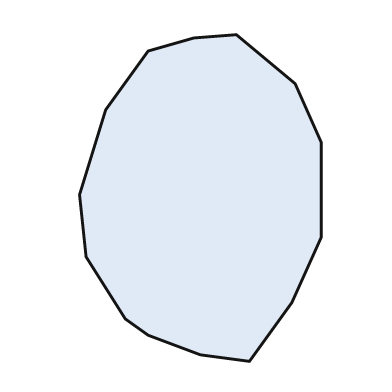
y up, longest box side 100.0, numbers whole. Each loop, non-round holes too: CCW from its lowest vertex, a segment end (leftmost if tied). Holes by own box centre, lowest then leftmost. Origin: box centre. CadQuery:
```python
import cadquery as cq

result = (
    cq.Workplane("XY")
    .moveTo(15.0, -50.0)
    .lineTo(28.0, -32.0)
    .lineTo(37.0, -12.0)
    .lineTo(37.0, 17.0)
    .lineTo(29.0, 35.0)
    .lineTo(11.0, 50.0)
    .lineTo(-2.0, 49.0)
    .lineTo(-16.0, 45.0)
    .lineTo(-29.0, 27.0)
    .lineTo(-37.0, 1.0)
    .lineTo(-35.0, -18.0)
    .lineTo(-23.0, -37.0)
    .lineTo(-16.0, -42.0)
    .lineTo(0.0, -48.0)
    .close()
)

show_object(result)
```